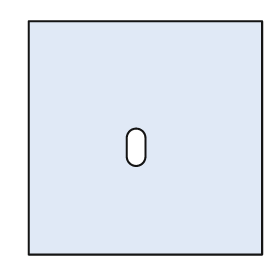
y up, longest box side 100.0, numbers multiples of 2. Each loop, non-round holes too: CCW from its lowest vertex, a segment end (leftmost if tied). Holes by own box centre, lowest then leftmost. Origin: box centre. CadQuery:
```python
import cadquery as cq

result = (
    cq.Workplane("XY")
    .moveTo(-50.0, -50.0)
    .lineTo(50.0, -50.0)
    .lineTo(50.0, 50.0)
    .lineTo(-50.0, 50.0)
    .close()
    .moveTo(-8.0, -8.0)
    .threePointArc((-4.0, -12.0), (0.0, -8.0))
    .lineTo(0.0, 0.0)
    .threePointArc((-4.0, 4.0), (-8.0, 0.0))
    .close()
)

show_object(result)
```